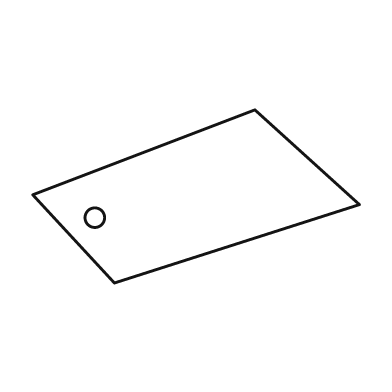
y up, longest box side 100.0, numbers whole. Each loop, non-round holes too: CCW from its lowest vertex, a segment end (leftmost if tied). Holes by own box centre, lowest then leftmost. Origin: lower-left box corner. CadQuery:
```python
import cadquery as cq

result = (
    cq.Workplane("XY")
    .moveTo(25.0, 0.0)
    .lineTo(100.0, 24.0)
    .lineTo(68.0, 53.0)
    .lineTo(0.0, 27.0)
    .close()
    .moveTo(19.0, 20.0)
    .circle(3.0)
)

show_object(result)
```